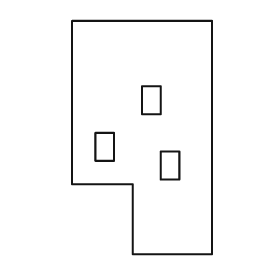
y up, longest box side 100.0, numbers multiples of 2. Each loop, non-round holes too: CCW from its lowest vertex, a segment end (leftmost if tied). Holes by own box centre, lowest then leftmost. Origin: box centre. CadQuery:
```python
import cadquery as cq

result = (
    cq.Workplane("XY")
    .moveTo(-4.0, -50.0)
    .lineTo(30.0, -50.0)
    .lineTo(30.0, 50.0)
    .lineTo(-30.0, 50.0)
    .lineTo(-30.0, -20.0)
    .lineTo(-4.0, -20.0)
    .close()
    .moveTo(8.0, -18.0)
    .lineTo(16.0, -18.0)
    .lineTo(16.0, -6.0)
    .lineTo(8.0, -6.0)
    .close()
    .moveTo(-20.0, -10.0)
    .lineTo(-12.0, -10.0)
    .lineTo(-12.0, 2.0)
    .lineTo(-20.0, 2.0)
    .close()
    .moveTo(0.0, 10.0)
    .lineTo(8.0, 10.0)
    .lineTo(8.0, 22.0)
    .lineTo(0.0, 22.0)
    .close()
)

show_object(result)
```